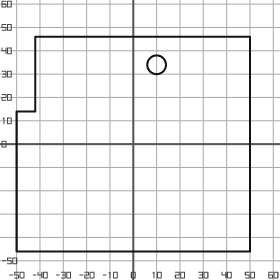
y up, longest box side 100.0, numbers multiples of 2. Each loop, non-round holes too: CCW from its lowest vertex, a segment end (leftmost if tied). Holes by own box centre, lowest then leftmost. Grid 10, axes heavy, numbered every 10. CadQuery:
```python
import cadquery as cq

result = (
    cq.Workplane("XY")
    .moveTo(-50.0, -46.0)
    .lineTo(50.0, -46.0)
    .lineTo(50.0, 46.0)
    .lineTo(-42.0, 46.0)
    .lineTo(-42.0, 14.0)
    .lineTo(-50.0, 14.0)
    .close()
    .moveTo(10.0, 34.0)
    .circle(4.0)
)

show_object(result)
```